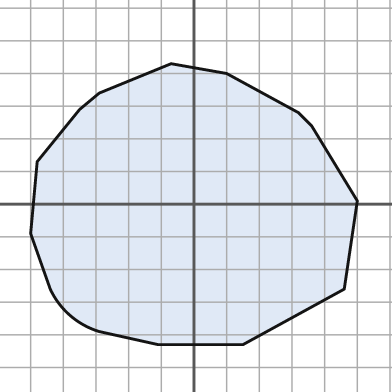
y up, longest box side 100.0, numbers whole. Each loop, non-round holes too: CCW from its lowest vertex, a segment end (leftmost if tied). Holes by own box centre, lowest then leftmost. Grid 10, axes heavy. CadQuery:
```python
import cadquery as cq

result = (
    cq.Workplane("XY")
    .moveTo(-11.0, -43.0)
    .lineTo(15.0, -43.0)
    .lineTo(46.0, -26.0)
    .lineTo(50.0, 1.0)
    .lineTo(36.0, 24.0)
    .lineTo(32.0, 28.0)
    .lineTo(10.0, 40.0)
    .lineTo(-7.0, 43.0)
    .lineTo(-29.0, 34.0)
    .lineTo(-35.0, 29.0)
    .lineTo(-48.0, 13.0)
    .lineTo(-50.0, -9.0)
    .lineTo(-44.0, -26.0)
    .threePointArc((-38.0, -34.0), (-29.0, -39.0))
    .close()
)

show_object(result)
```